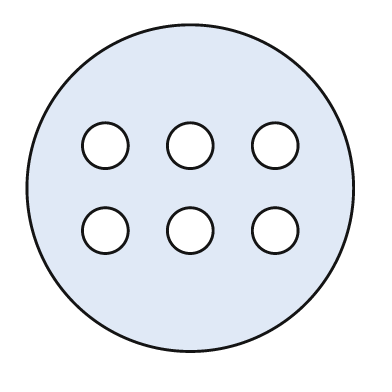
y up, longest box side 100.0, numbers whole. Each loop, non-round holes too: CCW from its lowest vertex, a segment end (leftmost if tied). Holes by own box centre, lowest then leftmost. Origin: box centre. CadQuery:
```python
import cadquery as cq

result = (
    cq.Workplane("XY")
    .moveTo(0.0, 0.0)
    .circle(50.0)
    .moveTo(-26.0, -13.0)
    .circle(7.0)
    .moveTo(0.0, -13.0)
    .circle(7.0)
    .moveTo(26.0, -13.0)
    .circle(7.0)
    .moveTo(-26.0, 13.0)
    .circle(7.0)
    .moveTo(0.0, 13.0)
    .circle(7.0)
    .moveTo(26.0, 13.0)
    .circle(7.0)
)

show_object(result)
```